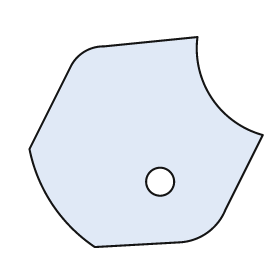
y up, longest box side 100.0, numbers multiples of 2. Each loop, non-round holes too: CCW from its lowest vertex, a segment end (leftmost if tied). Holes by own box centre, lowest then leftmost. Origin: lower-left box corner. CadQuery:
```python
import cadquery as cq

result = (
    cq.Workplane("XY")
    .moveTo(28.0, 0.0)
    .lineTo(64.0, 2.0)
    .threePointArc((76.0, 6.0), (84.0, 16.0))
    .lineTo(100.0, 48.0)
    .threePointArc((78.0, 64.0), (72.0, 90.0))
    .lineTo(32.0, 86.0)
    .threePointArc((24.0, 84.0), (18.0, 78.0))
    .lineTo(0.0, 42.0)
    .threePointArc((10.0, 18.0), (28.0, 0.0))
    .close()
    .moveTo(56.0, 28.0)
    .circle(6.0)
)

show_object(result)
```